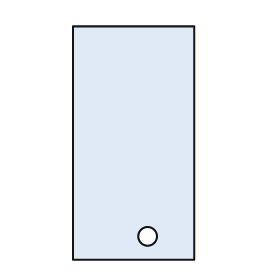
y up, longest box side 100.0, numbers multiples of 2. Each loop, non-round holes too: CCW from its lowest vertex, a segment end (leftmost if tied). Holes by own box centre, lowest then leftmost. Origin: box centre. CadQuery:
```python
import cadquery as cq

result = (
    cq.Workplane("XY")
    .moveTo(-26.0, -50.0)
    .lineTo(26.0, -50.0)
    .lineTo(26.0, 50.0)
    .lineTo(-26.0, 50.0)
    .close()
    .moveTo(6.0, -40.0)
    .circle(4.0)
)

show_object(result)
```